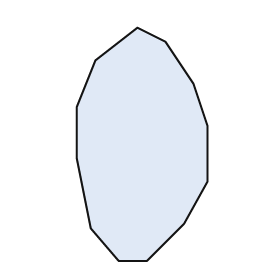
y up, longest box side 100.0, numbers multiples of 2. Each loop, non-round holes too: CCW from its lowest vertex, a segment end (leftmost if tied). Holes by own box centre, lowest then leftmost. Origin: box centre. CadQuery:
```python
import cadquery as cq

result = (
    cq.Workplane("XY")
    .moveTo(-10.0, -50.0)
    .lineTo(2.0, -50.0)
    .lineTo(18.0, -34.0)
    .lineTo(28.0, -16.0)
    .lineTo(28.0, 8.0)
    .lineTo(22.0, 26.0)
    .lineTo(10.0, 44.0)
    .lineTo(-2.0, 50.0)
    .lineTo(-20.0, 36.0)
    .lineTo(-28.0, 16.0)
    .lineTo(-28.0, -6.0)
    .lineTo(-22.0, -36.0)
    .close()
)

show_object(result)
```